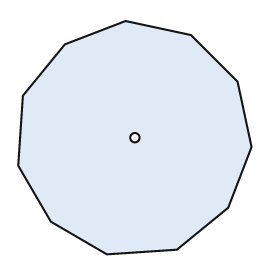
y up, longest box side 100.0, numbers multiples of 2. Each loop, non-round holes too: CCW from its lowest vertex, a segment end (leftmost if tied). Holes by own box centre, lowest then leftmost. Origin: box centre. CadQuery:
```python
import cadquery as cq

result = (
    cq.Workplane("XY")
    .moveTo(-12.0, -50.0)
    .lineTo(18.0, -48.0)
    .lineTo(40.0, -30.0)
    .lineTo(50.0, -4.0)
    .lineTo(44.0, 24.0)
    .lineTo(24.0, 44.0)
    .lineTo(-4.0, 50.0)
    .lineTo(-30.0, 40.0)
    .lineTo(-48.0, 18.0)
    .lineTo(-50.0, -12.0)
    .lineTo(-36.0, -36.0)
    .close()
    .moveTo(0.0, 0.0)
    .circle(2.0)
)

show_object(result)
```